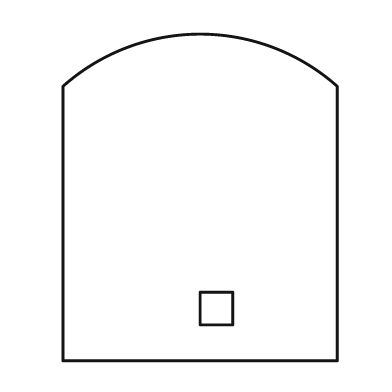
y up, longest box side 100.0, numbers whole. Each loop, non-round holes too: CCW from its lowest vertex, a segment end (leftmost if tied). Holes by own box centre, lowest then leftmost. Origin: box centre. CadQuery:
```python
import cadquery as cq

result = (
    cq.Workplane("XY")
    .moveTo(-42.0, -50.0)
    .lineTo(42.0, -50.0)
    .lineTo(42.0, 34.0)
    .threePointArc((0.0, 50.0), (-42.0, 34.0))
    .close()
    .moveTo(0.0, -39.0)
    .lineTo(10.0, -39.0)
    .lineTo(10.0, -29.0)
    .lineTo(0.0, -29.0)
    .close()
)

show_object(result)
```